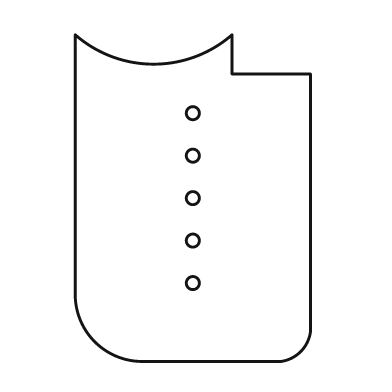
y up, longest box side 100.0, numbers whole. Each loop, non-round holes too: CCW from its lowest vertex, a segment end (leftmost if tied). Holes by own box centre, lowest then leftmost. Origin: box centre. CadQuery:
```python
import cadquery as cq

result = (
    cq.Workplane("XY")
    .moveTo(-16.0, -50.0)
    .lineTo(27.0, -50.0)
    .threePointArc((33.0, -47.0), (36.0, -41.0))
    .lineTo(36.0, 38.0)
    .lineTo(12.0, 38.0)
    .lineTo(12.0, 50.0)
    .threePointArc((-12.0, 41.0), (-36.0, 50.0))
    .lineTo(-36.0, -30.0)
    .threePointArc((-30.0, -44.0), (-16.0, -50.0))
    .close()
    .moveTo(0.0, -26.0)
    .circle(2.0)
    .moveTo(0.0, -13.0)
    .circle(2.0)
    .moveTo(0.0, 0.0)
    .circle(2.0)
    .moveTo(0.0, 13.0)
    .circle(2.0)
    .moveTo(0.0, 26.0)
    .circle(2.0)
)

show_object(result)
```